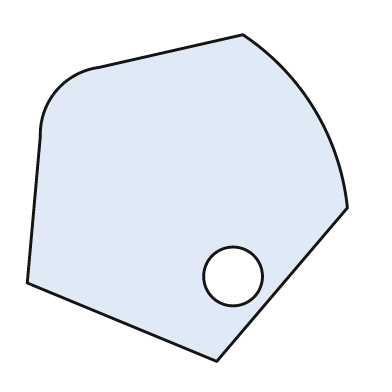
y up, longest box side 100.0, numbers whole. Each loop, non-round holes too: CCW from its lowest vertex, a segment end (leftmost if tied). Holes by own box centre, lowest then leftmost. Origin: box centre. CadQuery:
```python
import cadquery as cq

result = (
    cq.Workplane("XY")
    .moveTo(9.0, -50.0)
    .lineTo(49.0, -3.0)
    .threePointArc((39.0, 27.0), (17.0, 50.0))
    .lineTo(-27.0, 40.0)
    .threePointArc((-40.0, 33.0), (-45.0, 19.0))
    .lineTo(-49.0, -26.0)
    .close()
    .moveTo(14.0, -24.0)
    .circle(9.0)
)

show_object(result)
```